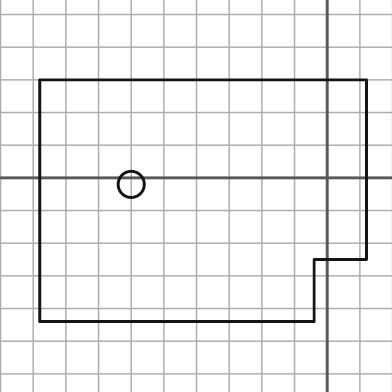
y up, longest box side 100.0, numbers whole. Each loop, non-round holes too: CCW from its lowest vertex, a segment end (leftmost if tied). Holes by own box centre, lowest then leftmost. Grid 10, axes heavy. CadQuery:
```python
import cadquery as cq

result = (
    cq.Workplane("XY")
    .moveTo(-88.0, -44.0)
    .lineTo(-4.0, -44.0)
    .lineTo(-4.0, -25.0)
    .lineTo(12.0, -25.0)
    .lineTo(12.0, 30.0)
    .lineTo(-88.0, 30.0)
    .close()
    .moveTo(-60.0, -2.0)
    .circle(4.0)
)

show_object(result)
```